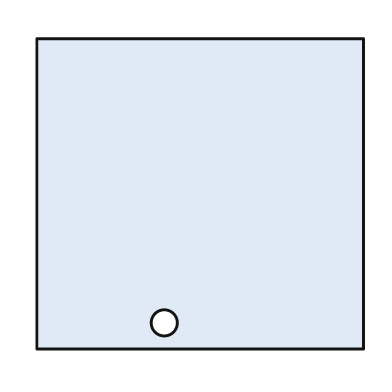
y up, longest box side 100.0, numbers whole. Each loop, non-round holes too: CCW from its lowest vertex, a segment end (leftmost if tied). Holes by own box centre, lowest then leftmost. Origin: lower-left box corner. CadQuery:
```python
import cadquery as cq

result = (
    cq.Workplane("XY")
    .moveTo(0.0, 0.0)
    .lineTo(100.0, 0.0)
    .lineTo(100.0, 95.0)
    .lineTo(0.0, 95.0)
    .close()
    .moveTo(39.0, 8.0)
    .circle(4.0)
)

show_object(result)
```